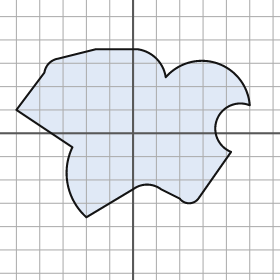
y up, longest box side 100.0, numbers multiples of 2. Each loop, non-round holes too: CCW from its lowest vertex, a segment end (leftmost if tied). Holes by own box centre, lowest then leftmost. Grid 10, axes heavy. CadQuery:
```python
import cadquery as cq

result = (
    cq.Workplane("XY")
    .moveTo(-20.0, -36.0)
    .lineTo(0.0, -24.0)
    .threePointArc((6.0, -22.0), (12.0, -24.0))
    .lineTo(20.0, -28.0)
    .threePointArc((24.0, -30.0), (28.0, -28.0))
    .lineTo(42.0, -8.0)
    .threePointArc((36.0, 6.0), (50.0, 12.0))
    .threePointArc((36.0, 30.0), (14.0, 24.0))
    .threePointArc((10.0, 32.0), (2.0, 36.0))
    .lineTo(-16.0, 36.0)
    .lineTo(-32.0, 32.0)
    .threePointArc((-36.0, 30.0), (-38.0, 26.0))
    .lineTo(-50.0, 10.0)
    .lineTo(-26.0, -6.0)
    .threePointArc((-28.0, -22.0), (-20.0, -36.0))
    .close()
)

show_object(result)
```